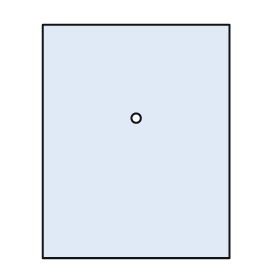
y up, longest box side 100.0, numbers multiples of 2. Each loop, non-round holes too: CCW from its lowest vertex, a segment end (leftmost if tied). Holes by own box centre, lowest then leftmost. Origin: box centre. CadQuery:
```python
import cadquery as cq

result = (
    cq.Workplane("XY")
    .moveTo(-40.0, -50.0)
    .lineTo(40.0, -50.0)
    .lineTo(40.0, 50.0)
    .lineTo(-40.0, 50.0)
    .close()
    .moveTo(0.0, 10.0)
    .circle(2.0)
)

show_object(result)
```